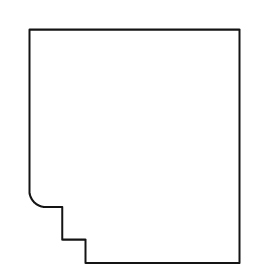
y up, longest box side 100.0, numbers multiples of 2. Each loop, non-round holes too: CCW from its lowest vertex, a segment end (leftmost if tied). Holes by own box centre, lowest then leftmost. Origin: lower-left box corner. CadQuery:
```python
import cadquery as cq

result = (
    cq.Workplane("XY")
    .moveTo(24.0, 0.0)
    .lineTo(90.0, 0.0)
    .lineTo(90.0, 100.0)
    .lineTo(0.0, 100.0)
    .lineTo(0.0, 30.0)
    .threePointArc((2.0, 26.0), (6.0, 24.0))
    .lineTo(14.0, 24.0)
    .lineTo(14.0, 10.0)
    .lineTo(24.0, 10.0)
    .close()
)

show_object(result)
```